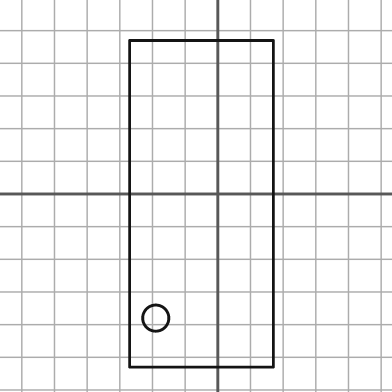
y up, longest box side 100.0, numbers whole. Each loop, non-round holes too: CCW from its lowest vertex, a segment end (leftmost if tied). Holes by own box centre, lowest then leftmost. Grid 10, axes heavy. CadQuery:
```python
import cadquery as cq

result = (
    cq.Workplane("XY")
    .moveTo(-27.0, -53.0)
    .lineTo(17.0, -53.0)
    .lineTo(17.0, 47.0)
    .lineTo(-27.0, 47.0)
    .close()
    .moveTo(-19.0, -38.0)
    .circle(4.0)
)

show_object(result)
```